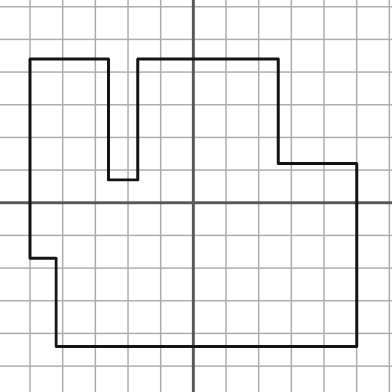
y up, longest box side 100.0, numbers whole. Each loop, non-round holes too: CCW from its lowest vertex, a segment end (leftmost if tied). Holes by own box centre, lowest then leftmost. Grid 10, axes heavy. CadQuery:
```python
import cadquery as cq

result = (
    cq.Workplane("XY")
    .moveTo(-42.0, -44.0)
    .lineTo(50.0, -44.0)
    .lineTo(50.0, 12.0)
    .lineTo(26.0, 12.0)
    .lineTo(26.0, 44.0)
    .lineTo(-17.0, 44.0)
    .lineTo(-17.0, 7.0)
    .lineTo(-26.0, 7.0)
    .lineTo(-26.0, 44.0)
    .lineTo(-50.0, 44.0)
    .lineTo(-50.0, -17.0)
    .lineTo(-42.0, -17.0)
    .close()
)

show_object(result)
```